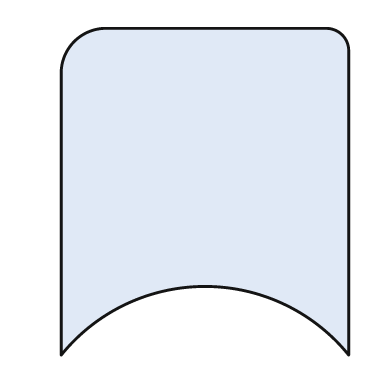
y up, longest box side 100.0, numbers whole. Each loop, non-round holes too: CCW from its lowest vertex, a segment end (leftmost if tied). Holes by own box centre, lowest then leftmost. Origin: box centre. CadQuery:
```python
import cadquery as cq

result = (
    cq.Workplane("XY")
    .moveTo(-44.0, -50.0)
    .threePointArc((0.0, -29.0), (44.0, -50.0))
    .lineTo(44.0, 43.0)
    .threePointArc((42.0, 48.0), (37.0, 50.0))
    .lineTo(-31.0, 50.0)
    .threePointArc((-40.0, 46.0), (-44.0, 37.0))
    .close()
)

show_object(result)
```